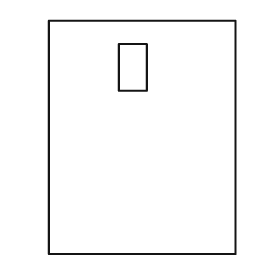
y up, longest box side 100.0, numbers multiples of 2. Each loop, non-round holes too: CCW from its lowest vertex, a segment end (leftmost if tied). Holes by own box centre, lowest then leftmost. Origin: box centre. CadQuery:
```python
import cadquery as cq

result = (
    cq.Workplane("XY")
    .moveTo(-40.0, -50.0)
    .lineTo(40.0, -50.0)
    .lineTo(40.0, 50.0)
    .lineTo(-40.0, 50.0)
    .close()
    .moveTo(-10.0, 20.0)
    .lineTo(2.0, 20.0)
    .lineTo(2.0, 40.0)
    .lineTo(-10.0, 40.0)
    .close()
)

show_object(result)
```